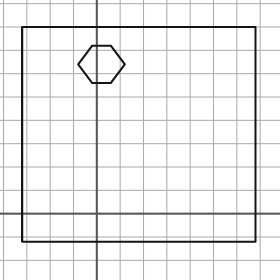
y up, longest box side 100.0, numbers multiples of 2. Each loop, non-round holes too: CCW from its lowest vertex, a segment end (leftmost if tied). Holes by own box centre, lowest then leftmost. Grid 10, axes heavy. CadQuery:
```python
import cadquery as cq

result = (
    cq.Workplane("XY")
    .moveTo(-32.0, -12.0)
    .lineTo(68.0, -12.0)
    .lineTo(68.0, 80.0)
    .lineTo(-32.0, 80.0)
    .close()
    .moveTo(-2.0, 56.0)
    .lineTo(6.0, 56.0)
    .lineTo(12.0, 64.0)
    .lineTo(6.0, 72.0)
    .lineTo(-2.0, 72.0)
    .lineTo(-8.0, 64.0)
    .close()
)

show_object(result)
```